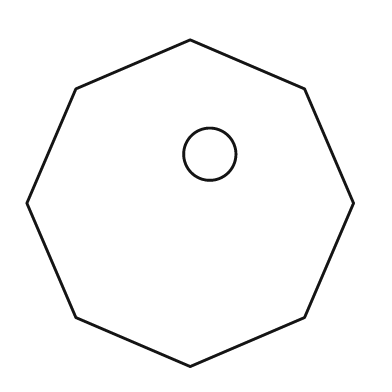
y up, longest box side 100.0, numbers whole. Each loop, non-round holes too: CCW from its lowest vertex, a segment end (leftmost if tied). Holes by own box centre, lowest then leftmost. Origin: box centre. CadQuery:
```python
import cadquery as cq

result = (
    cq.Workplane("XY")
    .moveTo(0.0, -50.0)
    .lineTo(35.0, -35.0)
    .lineTo(50.0, 0.0)
    .lineTo(35.0, 35.0)
    .lineTo(0.0, 50.0)
    .lineTo(-35.0, 35.0)
    .lineTo(-50.0, 0.0)
    .lineTo(-35.0, -35.0)
    .close()
    .moveTo(6.0, 15.0)
    .circle(8.0)
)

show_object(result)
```